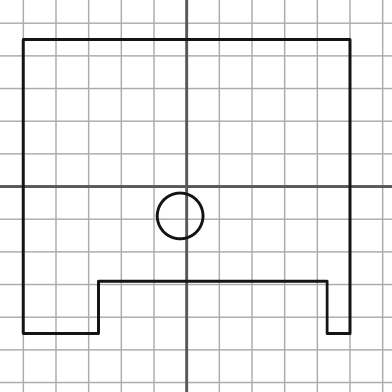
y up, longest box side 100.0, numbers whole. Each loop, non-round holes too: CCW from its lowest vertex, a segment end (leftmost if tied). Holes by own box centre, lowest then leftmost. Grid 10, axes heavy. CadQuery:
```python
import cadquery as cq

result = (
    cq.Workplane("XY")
    .moveTo(-50.0, -45.0)
    .lineTo(-27.0, -45.0)
    .lineTo(-27.0, -29.0)
    .lineTo(43.0, -29.0)
    .lineTo(43.0, -45.0)
    .lineTo(50.0, -45.0)
    .lineTo(50.0, 45.0)
    .lineTo(-50.0, 45.0)
    .close()
    .moveTo(-2.0, -9.0)
    .circle(7.0)
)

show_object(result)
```